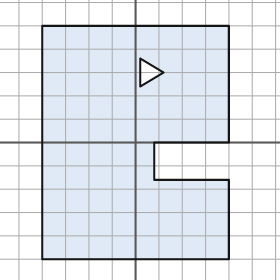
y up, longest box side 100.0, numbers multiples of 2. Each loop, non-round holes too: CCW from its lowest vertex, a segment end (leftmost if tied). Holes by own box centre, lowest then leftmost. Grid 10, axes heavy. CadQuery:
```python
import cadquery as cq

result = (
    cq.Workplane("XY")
    .moveTo(-40.0, -50.0)
    .lineTo(40.0, -50.0)
    .lineTo(40.0, -16.0)
    .lineTo(8.0, -16.0)
    .lineTo(8.0, 0.0)
    .lineTo(40.0, 0.0)
    .lineTo(40.0, 50.0)
    .lineTo(-40.0, 50.0)
    .close()
    .moveTo(2.0, 24.0)
    .lineTo(12.0, 30.0)
    .lineTo(2.0, 36.0)
    .close()
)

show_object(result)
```